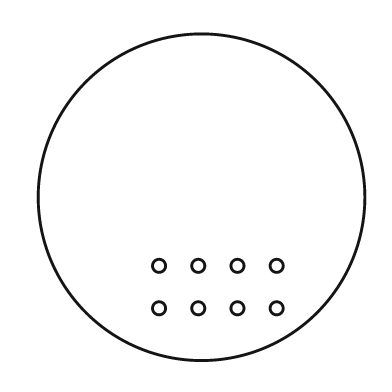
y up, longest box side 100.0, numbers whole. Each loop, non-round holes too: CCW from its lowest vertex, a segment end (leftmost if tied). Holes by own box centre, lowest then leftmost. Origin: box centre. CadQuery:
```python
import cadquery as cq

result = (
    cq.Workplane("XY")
    .moveTo(0.0, 0.0)
    .circle(50.0)
    .moveTo(-13.0, -34.0)
    .circle(2.0)
    .moveTo(-1.0, -34.0)
    .circle(2.0)
    .moveTo(11.0, -34.0)
    .circle(2.0)
    .moveTo(23.0, -34.0)
    .circle(2.0)
    .moveTo(-13.0, -21.0)
    .circle(2.0)
    .moveTo(-1.0, -21.0)
    .circle(2.0)
    .moveTo(11.0, -21.0)
    .circle(2.0)
    .moveTo(23.0, -21.0)
    .circle(2.0)
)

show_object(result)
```